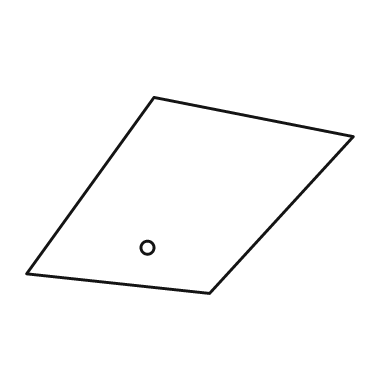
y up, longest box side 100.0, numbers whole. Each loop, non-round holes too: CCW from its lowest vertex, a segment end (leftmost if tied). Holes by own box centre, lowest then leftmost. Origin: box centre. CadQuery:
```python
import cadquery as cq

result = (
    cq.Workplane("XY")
    .moveTo(6.0, -30.0)
    .lineTo(50.0, 18.0)
    .lineTo(-11.0, 30.0)
    .lineTo(-50.0, -24.0)
    .close()
    .moveTo(-13.0, -16.0)
    .circle(2.0)
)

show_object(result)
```